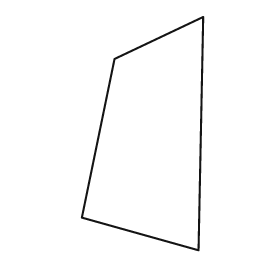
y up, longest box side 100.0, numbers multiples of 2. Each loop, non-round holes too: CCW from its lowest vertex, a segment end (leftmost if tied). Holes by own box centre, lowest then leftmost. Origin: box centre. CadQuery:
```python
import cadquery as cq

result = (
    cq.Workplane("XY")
    .moveTo(24.0, -50.0)
    .lineTo(26.0, 50.0)
    .lineTo(-12.0, 32.0)
    .lineTo(-26.0, -36.0)
    .close()
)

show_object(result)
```